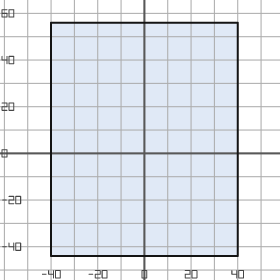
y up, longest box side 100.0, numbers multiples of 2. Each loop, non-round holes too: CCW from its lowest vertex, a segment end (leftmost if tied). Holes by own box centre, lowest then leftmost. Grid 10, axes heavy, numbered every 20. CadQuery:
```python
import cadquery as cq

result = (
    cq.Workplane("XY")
    .moveTo(-40.0, -44.0)
    .lineTo(40.0, -44.0)
    .lineTo(40.0, 56.0)
    .lineTo(-40.0, 56.0)
    .close()
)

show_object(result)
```